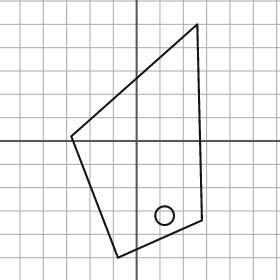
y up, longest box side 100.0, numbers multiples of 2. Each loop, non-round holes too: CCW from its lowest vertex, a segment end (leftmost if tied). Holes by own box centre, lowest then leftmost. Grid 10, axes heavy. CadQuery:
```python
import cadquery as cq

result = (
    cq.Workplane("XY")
    .moveTo(-8.0, -50.0)
    .lineTo(28.0, -34.0)
    .lineTo(26.0, 50.0)
    .lineTo(-28.0, 2.0)
    .close()
    .moveTo(12.0, -32.0)
    .circle(4.0)
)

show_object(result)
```